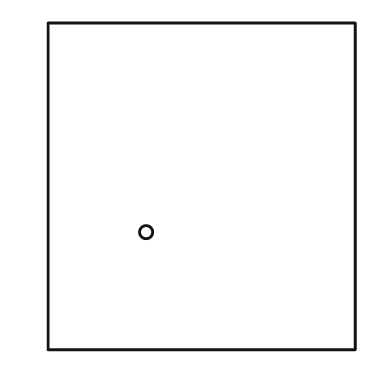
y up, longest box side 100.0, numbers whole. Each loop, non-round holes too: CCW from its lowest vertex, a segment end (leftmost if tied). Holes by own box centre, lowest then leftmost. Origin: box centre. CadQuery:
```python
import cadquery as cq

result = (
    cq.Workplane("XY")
    .moveTo(-47.0, -50.0)
    .lineTo(47.0, -50.0)
    .lineTo(47.0, 50.0)
    .lineTo(-47.0, 50.0)
    .close()
    .moveTo(-17.0, -14.0)
    .circle(2.0)
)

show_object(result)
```